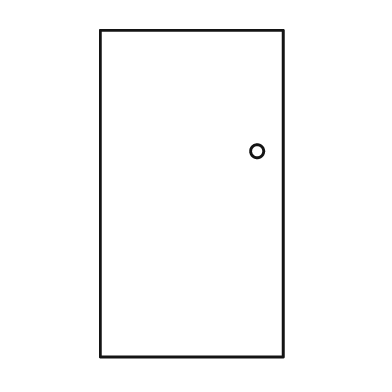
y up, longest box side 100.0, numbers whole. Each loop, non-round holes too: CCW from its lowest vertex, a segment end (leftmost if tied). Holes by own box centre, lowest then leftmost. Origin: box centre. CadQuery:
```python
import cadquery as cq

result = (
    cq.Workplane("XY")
    .moveTo(-28.0, -50.0)
    .lineTo(28.0, -50.0)
    .lineTo(28.0, 50.0)
    .lineTo(-28.0, 50.0)
    .close()
    .moveTo(20.0, 13.0)
    .circle(2.0)
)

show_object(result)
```